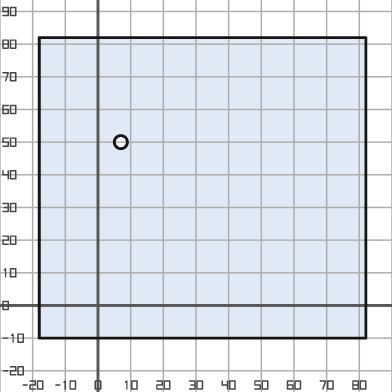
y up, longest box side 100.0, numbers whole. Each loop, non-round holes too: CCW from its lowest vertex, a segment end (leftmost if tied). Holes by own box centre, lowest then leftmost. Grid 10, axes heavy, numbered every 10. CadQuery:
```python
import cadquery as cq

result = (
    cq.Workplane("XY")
    .moveTo(-18.0, -10.0)
    .lineTo(82.0, -10.0)
    .lineTo(82.0, 82.0)
    .lineTo(-18.0, 82.0)
    .close()
    .moveTo(7.0, 50.0)
    .circle(2.0)
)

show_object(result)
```